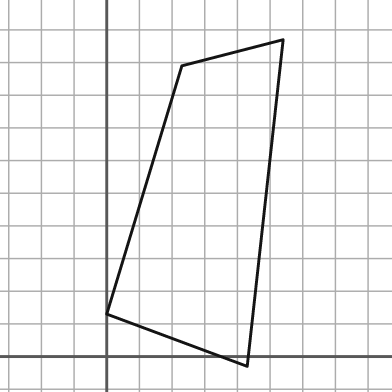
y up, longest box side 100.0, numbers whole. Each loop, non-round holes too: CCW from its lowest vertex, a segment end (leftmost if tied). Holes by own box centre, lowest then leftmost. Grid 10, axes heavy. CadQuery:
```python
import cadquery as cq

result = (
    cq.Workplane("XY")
    .moveTo(43.0, -3.0)
    .lineTo(54.0, 97.0)
    .lineTo(23.0, 89.0)
    .lineTo(0.0, 13.0)
    .close()
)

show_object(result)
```